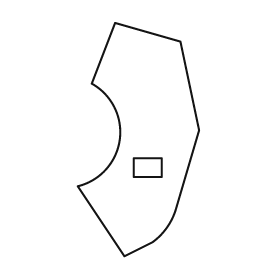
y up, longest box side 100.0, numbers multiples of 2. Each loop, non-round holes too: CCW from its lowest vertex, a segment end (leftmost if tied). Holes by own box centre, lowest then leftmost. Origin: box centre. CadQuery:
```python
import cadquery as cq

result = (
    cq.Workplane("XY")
    .moveTo(-6.0, -50.0)
    .lineTo(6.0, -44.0)
    .threePointArc((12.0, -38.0), (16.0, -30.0))
    .lineTo(26.0, 4.0)
    .lineTo(18.0, 42.0)
    .lineTo(-10.0, 50.0)
    .lineTo(-20.0, 24.0)
    .threePointArc((-8.0, 0.0), (-26.0, -20.0))
    .close()
    .moveTo(-2.0, -16.0)
    .lineTo(10.0, -16.0)
    .lineTo(10.0, -8.0)
    .lineTo(-2.0, -8.0)
    .close()
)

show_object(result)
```